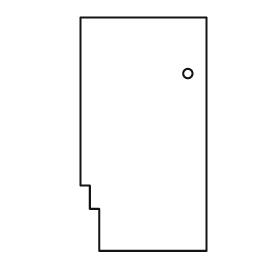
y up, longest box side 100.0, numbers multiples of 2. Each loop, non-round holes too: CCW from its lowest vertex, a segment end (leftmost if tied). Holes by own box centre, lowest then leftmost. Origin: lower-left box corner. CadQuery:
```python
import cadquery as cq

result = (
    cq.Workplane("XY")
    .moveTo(8.0, 0.0)
    .lineTo(54.0, 0.0)
    .lineTo(54.0, 100.0)
    .lineTo(0.0, 100.0)
    .lineTo(0.0, 28.0)
    .lineTo(4.0, 28.0)
    .lineTo(4.0, 18.0)
    .lineTo(8.0, 18.0)
    .close()
    .moveTo(46.0, 76.0)
    .circle(2.0)
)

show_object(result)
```